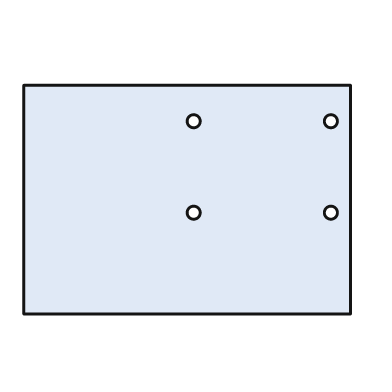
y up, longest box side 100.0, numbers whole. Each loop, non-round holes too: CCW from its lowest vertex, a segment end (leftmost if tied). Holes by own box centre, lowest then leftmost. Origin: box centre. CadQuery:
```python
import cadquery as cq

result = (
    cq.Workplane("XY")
    .moveTo(-50.0, -35.0)
    .lineTo(50.0, -35.0)
    .lineTo(50.0, 35.0)
    .lineTo(-50.0, 35.0)
    .close()
    .moveTo(2.0, -4.0)
    .circle(2.0)
    .moveTo(44.0, -4.0)
    .circle(2.0)
    .moveTo(2.0, 24.0)
    .circle(2.0)
    .moveTo(44.0, 24.0)
    .circle(2.0)
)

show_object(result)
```